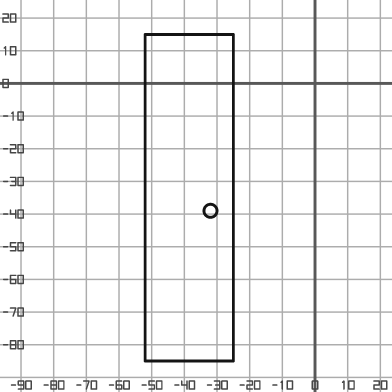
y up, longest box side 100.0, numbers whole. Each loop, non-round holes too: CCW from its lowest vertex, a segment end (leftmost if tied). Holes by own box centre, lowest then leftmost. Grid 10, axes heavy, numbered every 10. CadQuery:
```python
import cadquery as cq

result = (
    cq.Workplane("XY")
    .moveTo(-52.0, -85.0)
    .lineTo(-25.0, -85.0)
    .lineTo(-25.0, 15.0)
    .lineTo(-52.0, 15.0)
    .close()
    .moveTo(-32.0, -39.0)
    .circle(2.0)
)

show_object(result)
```